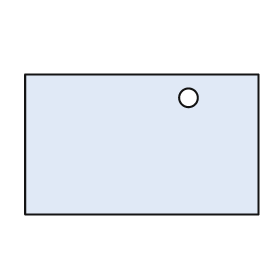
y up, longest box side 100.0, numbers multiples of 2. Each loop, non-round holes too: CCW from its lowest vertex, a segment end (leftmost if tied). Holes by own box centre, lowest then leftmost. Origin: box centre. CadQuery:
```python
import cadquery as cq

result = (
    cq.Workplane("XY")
    .moveTo(-50.0, -30.0)
    .lineTo(50.0, -30.0)
    .lineTo(50.0, 30.0)
    .lineTo(-50.0, 30.0)
    .close()
    .moveTo(20.0, 20.0)
    .circle(4.0)
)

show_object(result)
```